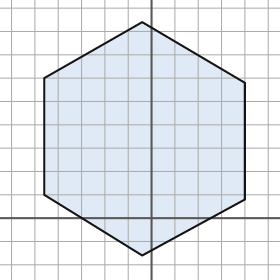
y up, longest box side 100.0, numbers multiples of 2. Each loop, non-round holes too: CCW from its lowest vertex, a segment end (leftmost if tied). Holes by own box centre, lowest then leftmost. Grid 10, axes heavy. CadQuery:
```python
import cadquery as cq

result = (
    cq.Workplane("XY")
    .moveTo(-4.0, -16.0)
    .lineTo(40.0, 8.0)
    .lineTo(40.0, 58.0)
    .lineTo(-4.0, 84.0)
    .lineTo(-46.0, 60.0)
    .lineTo(-46.0, 10.0)
    .close()
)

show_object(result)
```